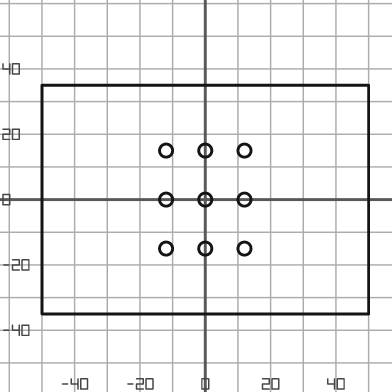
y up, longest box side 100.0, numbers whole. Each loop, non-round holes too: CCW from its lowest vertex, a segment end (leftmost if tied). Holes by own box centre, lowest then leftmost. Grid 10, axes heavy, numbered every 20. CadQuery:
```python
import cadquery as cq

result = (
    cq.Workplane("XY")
    .moveTo(-50.0, -35.0)
    .lineTo(50.0, -35.0)
    .lineTo(50.0, 35.0)
    .lineTo(-50.0, 35.0)
    .close()
    .moveTo(-12.0, -15.0)
    .circle(2.0)
    .moveTo(0.0, -15.0)
    .circle(2.0)
    .moveTo(12.0, -15.0)
    .circle(2.0)
    .moveTo(-12.0, 0.0)
    .circle(2.0)
    .moveTo(0.0, 0.0)
    .circle(2.0)
    .moveTo(12.0, 0.0)
    .circle(2.0)
    .moveTo(-12.0, 15.0)
    .circle(2.0)
    .moveTo(0.0, 15.0)
    .circle(2.0)
    .moveTo(12.0, 15.0)
    .circle(2.0)
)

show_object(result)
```